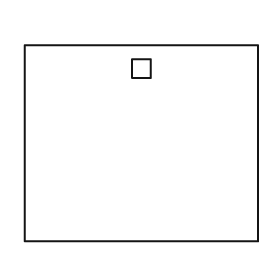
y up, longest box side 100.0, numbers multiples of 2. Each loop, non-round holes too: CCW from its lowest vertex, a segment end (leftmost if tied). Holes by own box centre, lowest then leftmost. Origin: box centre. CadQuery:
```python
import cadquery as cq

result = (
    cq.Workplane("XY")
    .moveTo(-50.0, -42.0)
    .lineTo(50.0, -42.0)
    .lineTo(50.0, 42.0)
    .lineTo(-50.0, 42.0)
    .close()
    .moveTo(-4.0, 28.0)
    .lineTo(4.0, 28.0)
    .lineTo(4.0, 36.0)
    .lineTo(-4.0, 36.0)
    .close()
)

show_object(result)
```